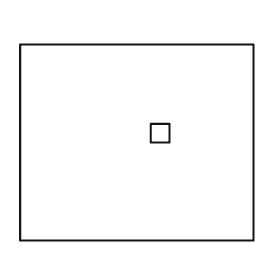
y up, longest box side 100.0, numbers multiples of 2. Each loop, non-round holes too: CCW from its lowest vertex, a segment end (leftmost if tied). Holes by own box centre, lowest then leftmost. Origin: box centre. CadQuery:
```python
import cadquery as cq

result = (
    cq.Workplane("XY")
    .moveTo(-50.0, -42.0)
    .lineTo(50.0, -42.0)
    .lineTo(50.0, 42.0)
    .lineTo(-50.0, 42.0)
    .close()
    .moveTo(6.0, 0.0)
    .lineTo(14.0, 0.0)
    .lineTo(14.0, 8.0)
    .lineTo(6.0, 8.0)
    .close()
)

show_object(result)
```